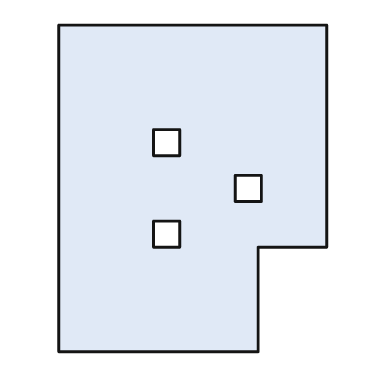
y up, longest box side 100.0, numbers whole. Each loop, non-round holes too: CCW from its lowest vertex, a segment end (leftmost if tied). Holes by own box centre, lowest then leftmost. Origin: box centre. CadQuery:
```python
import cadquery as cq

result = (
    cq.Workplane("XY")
    .moveTo(-41.0, -50.0)
    .lineTo(20.0, -50.0)
    .lineTo(20.0, -18.0)
    .lineTo(41.0, -18.0)
    .lineTo(41.0, 50.0)
    .lineTo(-41.0, 50.0)
    .close()
    .moveTo(-12.0, -18.0)
    .lineTo(-4.0, -18.0)
    .lineTo(-4.0, -10.0)
    .lineTo(-12.0, -10.0)
    .close()
    .moveTo(13.0, -4.0)
    .lineTo(21.0, -4.0)
    .lineTo(21.0, 4.0)
    .lineTo(13.0, 4.0)
    .close()
    .moveTo(-12.0, 10.0)
    .lineTo(-4.0, 10.0)
    .lineTo(-4.0, 18.0)
    .lineTo(-12.0, 18.0)
    .close()
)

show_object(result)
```